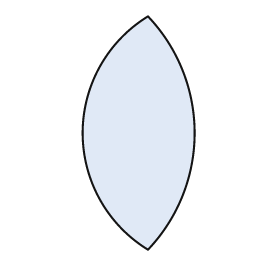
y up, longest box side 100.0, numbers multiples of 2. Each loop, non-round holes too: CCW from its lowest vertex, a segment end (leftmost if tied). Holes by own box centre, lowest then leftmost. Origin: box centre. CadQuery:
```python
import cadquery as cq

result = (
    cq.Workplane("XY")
    .moveTo(4.0, -50.0)
    .threePointArc((24.0, 0.0), (4.0, 50.0))
    .threePointArc((-24.0, 0.0), (4.0, -50.0))
    .close()
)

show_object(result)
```